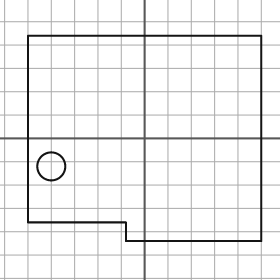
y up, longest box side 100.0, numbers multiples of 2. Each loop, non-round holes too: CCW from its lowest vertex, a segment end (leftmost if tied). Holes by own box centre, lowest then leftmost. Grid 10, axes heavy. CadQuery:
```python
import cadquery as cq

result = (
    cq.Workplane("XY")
    .moveTo(-8.0, -44.0)
    .lineTo(50.0, -44.0)
    .lineTo(50.0, 44.0)
    .lineTo(-50.0, 44.0)
    .lineTo(-50.0, -36.0)
    .lineTo(-8.0, -36.0)
    .close()
    .moveTo(-40.0, -12.0)
    .circle(6.0)
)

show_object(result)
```